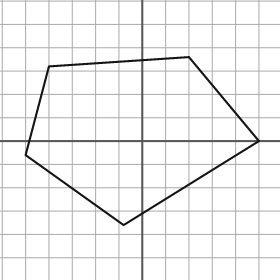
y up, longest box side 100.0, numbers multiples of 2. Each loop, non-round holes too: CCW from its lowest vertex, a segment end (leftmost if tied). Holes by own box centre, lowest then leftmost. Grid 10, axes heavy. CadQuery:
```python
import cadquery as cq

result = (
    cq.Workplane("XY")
    .moveTo(-8.0, -36.0)
    .lineTo(50.0, 0.0)
    .lineTo(20.0, 36.0)
    .lineTo(-40.0, 32.0)
    .lineTo(-50.0, -6.0)
    .close()
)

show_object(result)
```